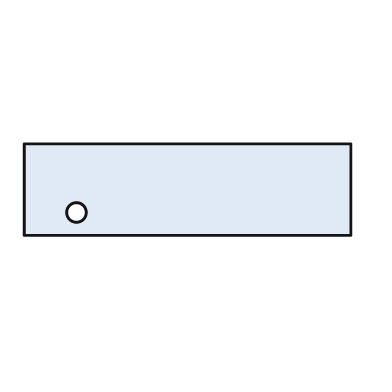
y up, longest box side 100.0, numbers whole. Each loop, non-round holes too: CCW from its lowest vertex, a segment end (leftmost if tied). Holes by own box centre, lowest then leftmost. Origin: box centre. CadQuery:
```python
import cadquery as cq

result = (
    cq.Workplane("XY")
    .moveTo(-50.0, -14.0)
    .lineTo(50.0, -14.0)
    .lineTo(50.0, 14.0)
    .lineTo(-50.0, 14.0)
    .close()
    .moveTo(-34.0, -7.0)
    .circle(3.0)
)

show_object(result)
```